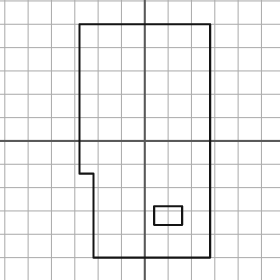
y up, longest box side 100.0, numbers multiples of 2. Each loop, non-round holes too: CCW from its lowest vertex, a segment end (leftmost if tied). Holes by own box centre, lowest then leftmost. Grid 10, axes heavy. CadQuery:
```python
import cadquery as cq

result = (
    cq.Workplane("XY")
    .moveTo(-22.0, -50.0)
    .lineTo(28.0, -50.0)
    .lineTo(28.0, 50.0)
    .lineTo(-28.0, 50.0)
    .lineTo(-28.0, -14.0)
    .lineTo(-22.0, -14.0)
    .close()
    .moveTo(4.0, -36.0)
    .lineTo(16.0, -36.0)
    .lineTo(16.0, -28.0)
    .lineTo(4.0, -28.0)
    .close()
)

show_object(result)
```